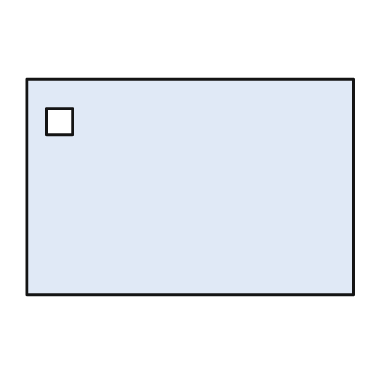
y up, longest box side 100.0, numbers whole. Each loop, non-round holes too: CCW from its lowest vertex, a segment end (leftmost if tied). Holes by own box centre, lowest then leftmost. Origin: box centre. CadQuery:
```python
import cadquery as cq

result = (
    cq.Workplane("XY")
    .moveTo(-50.0, -33.0)
    .lineTo(50.0, -33.0)
    .lineTo(50.0, 33.0)
    .lineTo(-50.0, 33.0)
    .close()
    .moveTo(-44.0, 16.0)
    .lineTo(-36.0, 16.0)
    .lineTo(-36.0, 24.0)
    .lineTo(-44.0, 24.0)
    .close()
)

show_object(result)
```